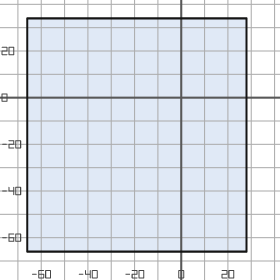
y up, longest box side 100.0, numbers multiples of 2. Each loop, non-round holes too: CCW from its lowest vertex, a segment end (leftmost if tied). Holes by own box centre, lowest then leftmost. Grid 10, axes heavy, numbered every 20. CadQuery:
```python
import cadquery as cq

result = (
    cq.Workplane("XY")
    .moveTo(-66.0, -66.0)
    .lineTo(28.0, -66.0)
    .lineTo(28.0, 34.0)
    .lineTo(-66.0, 34.0)
    .close()
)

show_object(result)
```